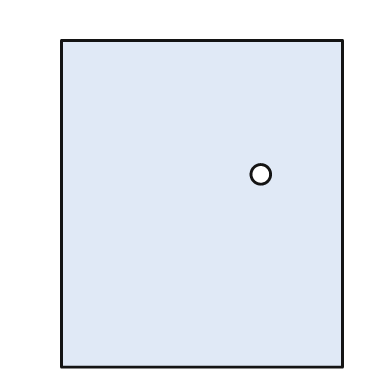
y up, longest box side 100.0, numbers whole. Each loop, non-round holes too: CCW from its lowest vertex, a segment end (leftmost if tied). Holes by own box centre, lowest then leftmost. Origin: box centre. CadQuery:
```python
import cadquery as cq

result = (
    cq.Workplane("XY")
    .moveTo(-43.0, -50.0)
    .lineTo(43.0, -50.0)
    .lineTo(43.0, 50.0)
    .lineTo(-43.0, 50.0)
    .close()
    .moveTo(18.0, 9.0)
    .circle(3.0)
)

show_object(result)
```